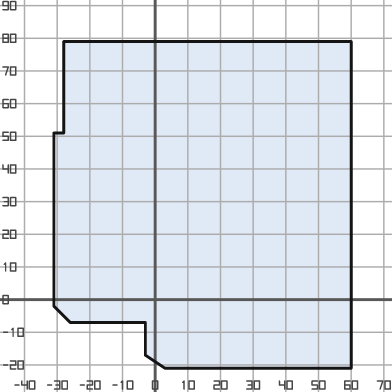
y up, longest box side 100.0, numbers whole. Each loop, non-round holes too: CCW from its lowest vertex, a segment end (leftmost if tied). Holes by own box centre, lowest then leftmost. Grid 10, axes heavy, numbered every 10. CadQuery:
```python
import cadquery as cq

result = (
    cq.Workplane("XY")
    .moveTo(3.0, -21.0)
    .lineTo(60.0, -21.0)
    .lineTo(60.0, 79.0)
    .lineTo(-28.0, 79.0)
    .lineTo(-28.0, 51.0)
    .lineTo(-31.0, 51.0)
    .lineTo(-31.0, -2.0)
    .lineTo(-26.0, -7.0)
    .lineTo(-3.0, -7.0)
    .lineTo(-3.0, -17.0)
    .close()
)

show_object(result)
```